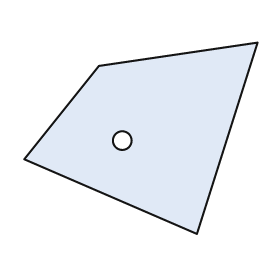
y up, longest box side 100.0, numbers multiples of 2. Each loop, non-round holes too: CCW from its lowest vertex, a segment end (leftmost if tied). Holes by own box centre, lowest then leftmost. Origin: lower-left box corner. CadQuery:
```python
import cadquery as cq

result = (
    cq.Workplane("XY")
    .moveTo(74.0, 0.0)
    .lineTo(100.0, 82.0)
    .lineTo(32.0, 72.0)
    .lineTo(0.0, 32.0)
    .close()
    .moveTo(42.0, 40.0)
    .circle(4.0)
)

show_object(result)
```